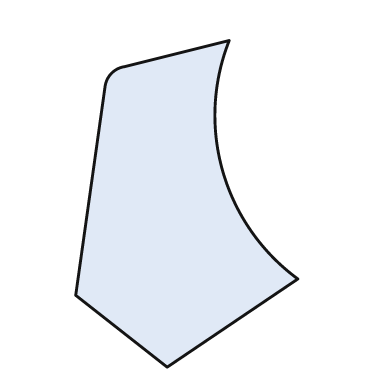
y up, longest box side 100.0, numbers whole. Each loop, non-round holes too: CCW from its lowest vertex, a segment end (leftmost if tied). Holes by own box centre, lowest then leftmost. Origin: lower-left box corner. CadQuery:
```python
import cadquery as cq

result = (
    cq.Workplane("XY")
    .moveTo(28.0, 0.0)
    .lineTo(68.0, 27.0)
    .threePointArc((45.0, 60.0), (47.0, 100.0))
    .lineTo(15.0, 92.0)
    .threePointArc((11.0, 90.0), (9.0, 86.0))
    .lineTo(0.0, 22.0)
    .close()
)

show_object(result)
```